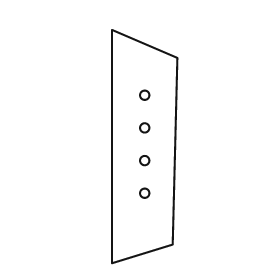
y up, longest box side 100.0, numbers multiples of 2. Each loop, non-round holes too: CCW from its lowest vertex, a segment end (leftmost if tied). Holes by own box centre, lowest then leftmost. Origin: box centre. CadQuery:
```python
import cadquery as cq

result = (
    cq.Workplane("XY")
    .moveTo(-14.0, -50.0)
    .lineTo(12.0, -42.0)
    .lineTo(14.0, 38.0)
    .lineTo(-14.0, 50.0)
    .close()
    .moveTo(0.0, -20.0)
    .circle(2.0)
    .moveTo(0.0, -6.0)
    .circle(2.0)
    .moveTo(0.0, 8.0)
    .circle(2.0)
    .moveTo(0.0, 22.0)
    .circle(2.0)
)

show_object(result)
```